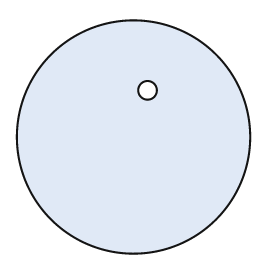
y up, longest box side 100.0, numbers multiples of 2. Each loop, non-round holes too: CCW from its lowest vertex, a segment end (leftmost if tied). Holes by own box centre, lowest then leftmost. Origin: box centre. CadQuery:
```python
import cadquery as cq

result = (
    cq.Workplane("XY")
    .moveTo(0.0, 0.0)
    .circle(50.0)
    .moveTo(6.0, 20.0)
    .circle(4.0)
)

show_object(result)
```